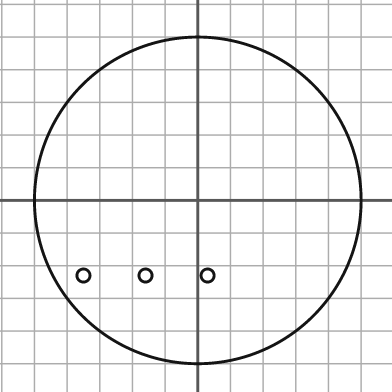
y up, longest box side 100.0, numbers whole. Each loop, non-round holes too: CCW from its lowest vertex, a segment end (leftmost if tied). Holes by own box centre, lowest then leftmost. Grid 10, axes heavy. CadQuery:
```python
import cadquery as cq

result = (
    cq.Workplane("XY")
    .moveTo(0.0, 0.0)
    .circle(50.0)
    .moveTo(-35.0, -23.0)
    .circle(2.0)
    .moveTo(-16.0, -23.0)
    .circle(2.0)
    .moveTo(3.0, -23.0)
    .circle(2.0)
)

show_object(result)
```